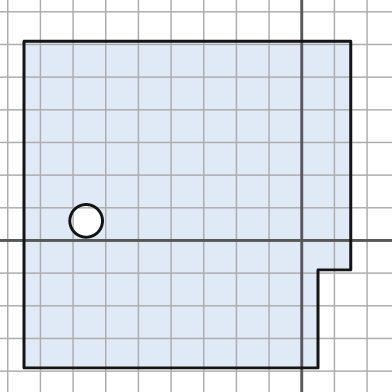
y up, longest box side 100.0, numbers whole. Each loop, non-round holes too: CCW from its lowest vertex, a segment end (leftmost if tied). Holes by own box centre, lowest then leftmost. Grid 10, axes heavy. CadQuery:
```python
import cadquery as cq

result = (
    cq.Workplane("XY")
    .moveTo(-85.0, -39.0)
    .lineTo(5.0, -39.0)
    .lineTo(5.0, -9.0)
    .lineTo(15.0, -9.0)
    .lineTo(15.0, 61.0)
    .lineTo(-85.0, 61.0)
    .close()
    .moveTo(-66.0, 6.0)
    .circle(5.0)
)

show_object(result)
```